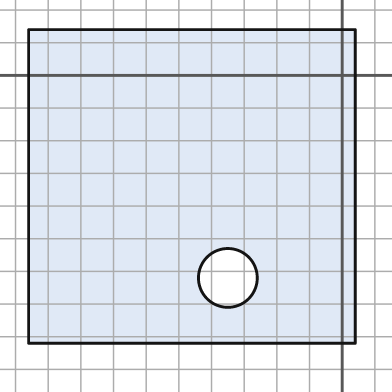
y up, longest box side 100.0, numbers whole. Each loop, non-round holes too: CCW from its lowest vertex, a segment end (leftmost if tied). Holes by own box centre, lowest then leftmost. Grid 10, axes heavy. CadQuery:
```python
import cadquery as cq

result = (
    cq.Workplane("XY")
    .moveTo(-96.0, -82.0)
    .lineTo(4.0, -82.0)
    .lineTo(4.0, 14.0)
    .lineTo(-96.0, 14.0)
    .close()
    .moveTo(-35.0, -62.0)
    .circle(9.0)
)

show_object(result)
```